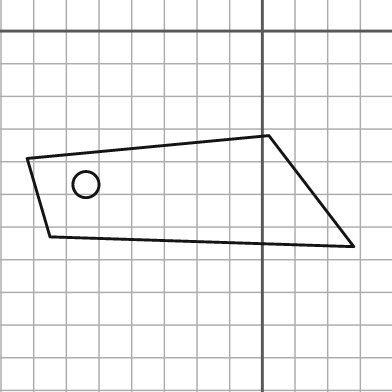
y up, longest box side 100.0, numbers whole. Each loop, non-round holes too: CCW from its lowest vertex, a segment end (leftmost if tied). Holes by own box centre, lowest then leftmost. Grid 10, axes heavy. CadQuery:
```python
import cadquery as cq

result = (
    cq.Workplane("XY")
    .moveTo(28.0, -66.0)
    .lineTo(2.0, -32.0)
    .lineTo(-72.0, -39.0)
    .lineTo(-65.0, -63.0)
    .close()
    .moveTo(-54.0, -47.0)
    .circle(4.0)
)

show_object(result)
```